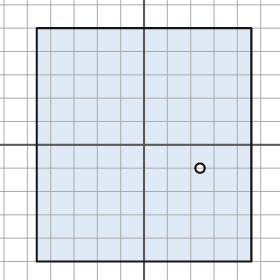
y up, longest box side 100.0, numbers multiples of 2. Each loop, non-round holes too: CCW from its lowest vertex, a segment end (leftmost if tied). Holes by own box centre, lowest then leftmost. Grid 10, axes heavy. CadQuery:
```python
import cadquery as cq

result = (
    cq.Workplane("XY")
    .moveTo(-46.0, -50.0)
    .lineTo(46.0, -50.0)
    .lineTo(46.0, 50.0)
    .lineTo(-46.0, 50.0)
    .close()
    .moveTo(24.0, -10.0)
    .circle(2.0)
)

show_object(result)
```